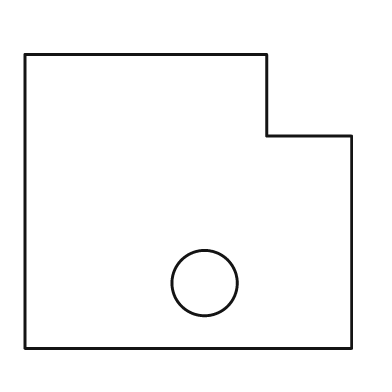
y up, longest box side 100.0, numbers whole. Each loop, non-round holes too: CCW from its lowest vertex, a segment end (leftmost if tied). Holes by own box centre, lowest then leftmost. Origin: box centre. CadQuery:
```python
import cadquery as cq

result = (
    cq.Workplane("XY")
    .moveTo(-50.0, -45.0)
    .lineTo(50.0, -45.0)
    .lineTo(50.0, 20.0)
    .lineTo(24.0, 20.0)
    .lineTo(24.0, 45.0)
    .lineTo(-50.0, 45.0)
    .close()
    .moveTo(5.0, -25.0)
    .circle(10.0)
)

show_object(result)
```